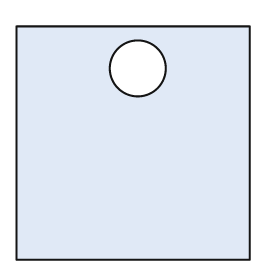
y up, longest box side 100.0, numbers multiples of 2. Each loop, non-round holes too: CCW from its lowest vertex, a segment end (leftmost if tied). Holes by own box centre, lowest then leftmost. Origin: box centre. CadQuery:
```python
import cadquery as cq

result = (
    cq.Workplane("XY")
    .moveTo(-50.0, -50.0)
    .lineTo(50.0, -50.0)
    .lineTo(50.0, 50.0)
    .lineTo(-50.0, 50.0)
    .close()
    .moveTo(2.0, 32.0)
    .circle(12.0)
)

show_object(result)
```